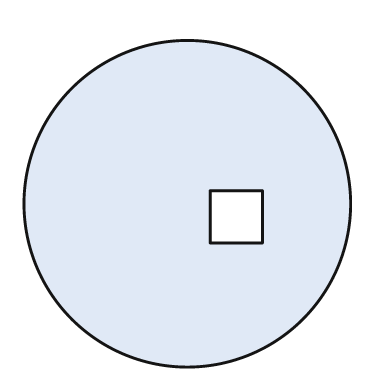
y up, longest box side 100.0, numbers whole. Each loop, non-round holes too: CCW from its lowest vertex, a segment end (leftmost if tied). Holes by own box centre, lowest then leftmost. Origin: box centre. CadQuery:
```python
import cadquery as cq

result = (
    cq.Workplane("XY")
    .moveTo(0.0, 0.0)
    .circle(50.0)
    .moveTo(7.0, -12.0)
    .lineTo(23.0, -12.0)
    .lineTo(23.0, 4.0)
    .lineTo(7.0, 4.0)
    .close()
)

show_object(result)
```